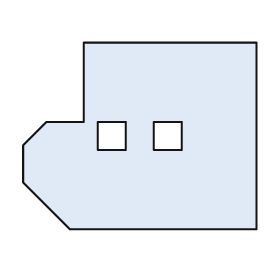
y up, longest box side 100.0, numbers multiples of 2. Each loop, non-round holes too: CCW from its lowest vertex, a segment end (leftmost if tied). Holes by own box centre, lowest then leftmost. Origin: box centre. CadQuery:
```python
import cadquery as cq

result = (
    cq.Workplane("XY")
    .moveTo(-30.0, -40.0)
    .lineTo(50.0, -40.0)
    .lineTo(50.0, 40.0)
    .lineTo(-24.0, 40.0)
    .lineTo(-24.0, 6.0)
    .lineTo(-40.0, 6.0)
    .lineTo(-50.0, -4.0)
    .lineTo(-50.0, -20.0)
    .close()
    .moveTo(-18.0, -6.0)
    .lineTo(-6.0, -6.0)
    .lineTo(-6.0, 6.0)
    .lineTo(-18.0, 6.0)
    .close()
    .moveTo(6.0, -6.0)
    .lineTo(18.0, -6.0)
    .lineTo(18.0, 6.0)
    .lineTo(6.0, 6.0)
    .close()
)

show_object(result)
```